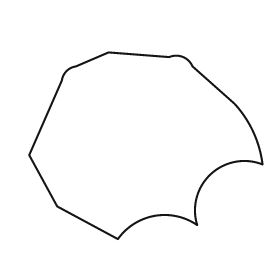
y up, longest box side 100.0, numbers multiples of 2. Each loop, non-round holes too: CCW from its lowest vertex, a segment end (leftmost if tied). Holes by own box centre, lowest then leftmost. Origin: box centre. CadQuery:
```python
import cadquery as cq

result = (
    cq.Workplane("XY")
    .moveTo(-12.0, -40.0)
    .threePointArc((4.0, -30.0), (22.0, -34.0))
    .threePointArc((28.0, -12.0), (50.0, -8.0))
    .threePointArc((46.0, 6.0), (38.0, 18.0))
    .lineTo(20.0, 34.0)
    .threePointArc((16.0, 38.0), (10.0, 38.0))
    .lineTo(-16.0, 40.0)
    .lineTo(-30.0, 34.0)
    .threePointArc((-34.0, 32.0), (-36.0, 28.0))
    .lineTo(-50.0, -4.0)
    .lineTo(-38.0, -26.0)
    .close()
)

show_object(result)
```